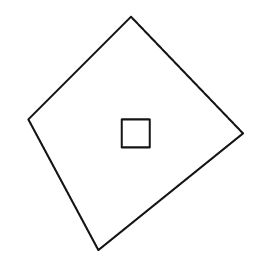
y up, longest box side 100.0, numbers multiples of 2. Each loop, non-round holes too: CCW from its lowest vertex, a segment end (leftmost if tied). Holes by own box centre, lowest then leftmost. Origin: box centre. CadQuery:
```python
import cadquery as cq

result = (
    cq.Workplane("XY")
    .moveTo(-16.0, -50.0)
    .lineTo(46.0, 0.0)
    .lineTo(-2.0, 50.0)
    .lineTo(-46.0, 6.0)
    .close()
    .moveTo(-6.0, -6.0)
    .lineTo(6.0, -6.0)
    .lineTo(6.0, 6.0)
    .lineTo(-6.0, 6.0)
    .close()
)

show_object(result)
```